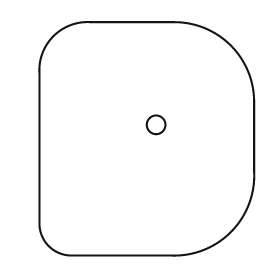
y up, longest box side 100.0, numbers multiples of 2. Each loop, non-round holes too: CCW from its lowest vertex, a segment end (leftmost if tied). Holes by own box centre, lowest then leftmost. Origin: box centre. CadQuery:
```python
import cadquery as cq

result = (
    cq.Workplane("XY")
    .moveTo(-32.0, -50.0)
    .lineTo(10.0, -50.0)
    .threePointArc((36.0, -40.0), (46.0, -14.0))
    .lineTo(46.0, 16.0)
    .threePointArc((36.0, 40.0), (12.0, 50.0))
    .lineTo(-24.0, 50.0)
    .threePointArc((-40.0, 44.0), (-46.0, 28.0))
    .lineTo(-46.0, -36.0)
    .threePointArc((-42.0, -46.0), (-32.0, -50.0))
    .close()
    .moveTo(4.0, 6.0)
    .circle(4.0)
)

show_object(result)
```